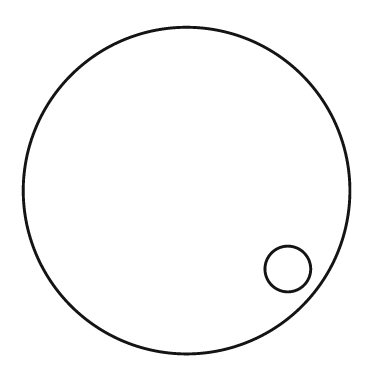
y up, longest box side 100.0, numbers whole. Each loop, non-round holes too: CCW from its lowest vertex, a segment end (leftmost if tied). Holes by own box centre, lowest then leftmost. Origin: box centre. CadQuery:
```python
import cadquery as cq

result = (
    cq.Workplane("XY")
    .moveTo(0.0, 0.0)
    .circle(50.0)
    .moveTo(31.0, -24.0)
    .circle(7.0)
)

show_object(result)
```